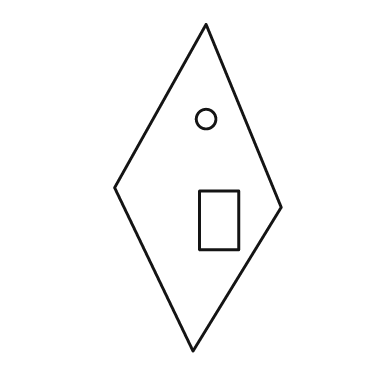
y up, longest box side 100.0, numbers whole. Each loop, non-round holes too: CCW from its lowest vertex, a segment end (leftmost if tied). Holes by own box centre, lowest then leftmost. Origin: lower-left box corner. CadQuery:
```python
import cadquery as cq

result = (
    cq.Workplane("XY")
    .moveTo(24.0, 0.0)
    .lineTo(51.0, 44.0)
    .lineTo(28.0, 100.0)
    .lineTo(0.0, 50.0)
    .close()
    .moveTo(26.0, 31.0)
    .lineTo(38.0, 31.0)
    .lineTo(38.0, 49.0)
    .lineTo(26.0, 49.0)
    .close()
    .moveTo(28.0, 71.0)
    .circle(3.0)
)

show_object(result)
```